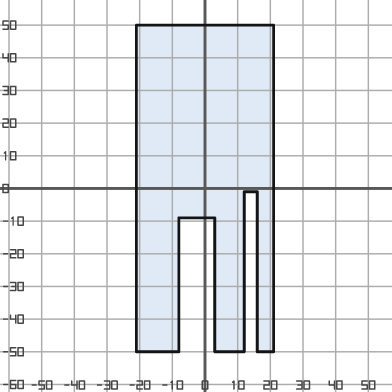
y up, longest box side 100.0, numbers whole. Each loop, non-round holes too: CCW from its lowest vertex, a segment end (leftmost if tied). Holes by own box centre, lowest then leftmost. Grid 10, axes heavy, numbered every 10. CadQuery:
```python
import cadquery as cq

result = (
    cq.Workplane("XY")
    .moveTo(-21.0, -50.0)
    .lineTo(-8.0, -50.0)
    .lineTo(-8.0, -9.0)
    .lineTo(3.0, -9.0)
    .lineTo(3.0, -50.0)
    .lineTo(12.0, -50.0)
    .lineTo(12.0, -1.0)
    .lineTo(16.0, -1.0)
    .lineTo(16.0, -50.0)
    .lineTo(21.0, -50.0)
    .lineTo(21.0, 50.0)
    .lineTo(-21.0, 50.0)
    .close()
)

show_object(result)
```